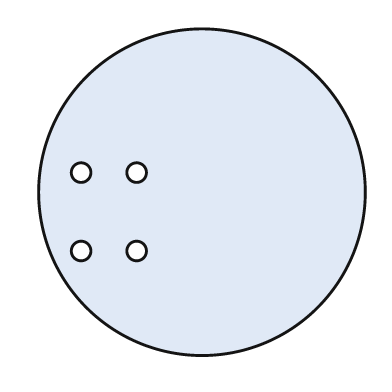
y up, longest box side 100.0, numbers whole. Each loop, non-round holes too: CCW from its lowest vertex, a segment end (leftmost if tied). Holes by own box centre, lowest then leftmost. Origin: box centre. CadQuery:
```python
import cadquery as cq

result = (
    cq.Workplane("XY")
    .moveTo(0.0, 0.0)
    .circle(50.0)
    .moveTo(-37.0, -18.0)
    .circle(3.0)
    .moveTo(-20.0, -18.0)
    .circle(3.0)
    .moveTo(-37.0, 6.0)
    .circle(3.0)
    .moveTo(-20.0, 6.0)
    .circle(3.0)
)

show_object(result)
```